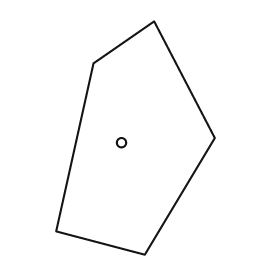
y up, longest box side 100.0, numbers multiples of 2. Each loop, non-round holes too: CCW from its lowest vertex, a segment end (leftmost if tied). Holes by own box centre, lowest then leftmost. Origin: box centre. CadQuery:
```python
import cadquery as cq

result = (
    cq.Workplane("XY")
    .moveTo(4.0, -50.0)
    .lineTo(34.0, 0.0)
    .lineTo(8.0, 50.0)
    .lineTo(-18.0, 32.0)
    .lineTo(-34.0, -40.0)
    .close()
    .moveTo(-6.0, -2.0)
    .circle(2.0)
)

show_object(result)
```